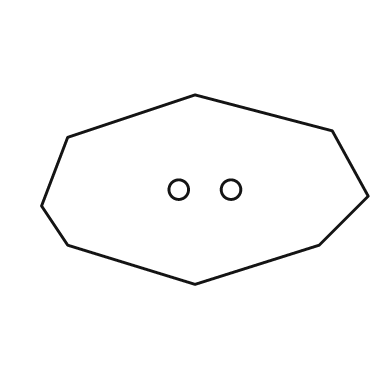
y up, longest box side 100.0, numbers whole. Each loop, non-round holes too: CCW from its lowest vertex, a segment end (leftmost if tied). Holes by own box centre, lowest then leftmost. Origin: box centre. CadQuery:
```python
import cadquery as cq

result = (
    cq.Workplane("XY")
    .moveTo(-3.0, -29.0)
    .lineTo(35.0, -17.0)
    .lineTo(50.0, -2.0)
    .lineTo(39.0, 18.0)
    .lineTo(-3.0, 29.0)
    .lineTo(-42.0, 16.0)
    .lineTo(-50.0, -5.0)
    .lineTo(-42.0, -17.0)
    .close()
    .moveTo(-8.0, 0.0)
    .circle(3.0)
    .moveTo(8.0, 0.0)
    .circle(3.0)
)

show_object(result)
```